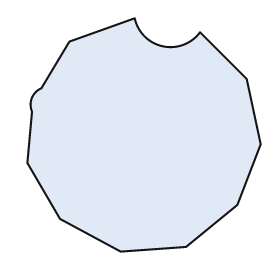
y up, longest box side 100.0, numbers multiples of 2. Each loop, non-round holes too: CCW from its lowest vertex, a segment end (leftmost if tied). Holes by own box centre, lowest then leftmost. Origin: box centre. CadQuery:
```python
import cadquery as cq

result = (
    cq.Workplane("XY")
    .moveTo(-10.0, -50.0)
    .lineTo(18.0, -48.0)
    .lineTo(40.0, -30.0)
    .lineTo(50.0, -4.0)
    .lineTo(44.0, 24.0)
    .lineTo(24.0, 44.0)
    .threePointArc((8.0, 38.0), (-4.0, 50.0))
    .lineTo(-32.0, 40.0)
    .lineTo(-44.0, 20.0)
    .threePointArc((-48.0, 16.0), (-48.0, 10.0))
    .lineTo(-50.0, -12.0)
    .lineTo(-36.0, -36.0)
    .close()
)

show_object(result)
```